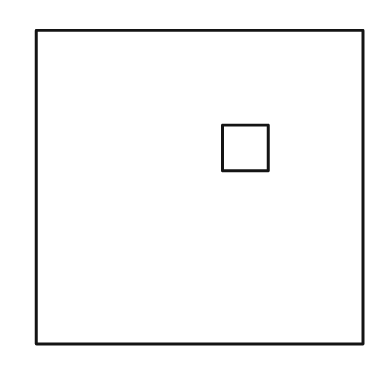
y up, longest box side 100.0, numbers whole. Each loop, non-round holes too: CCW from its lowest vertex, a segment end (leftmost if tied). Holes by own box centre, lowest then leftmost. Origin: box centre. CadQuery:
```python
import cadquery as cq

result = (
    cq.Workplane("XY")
    .moveTo(-50.0, -48.0)
    .lineTo(50.0, -48.0)
    .lineTo(50.0, 48.0)
    .lineTo(-50.0, 48.0)
    .close()
    .moveTo(7.0, 5.0)
    .lineTo(21.0, 5.0)
    .lineTo(21.0, 19.0)
    .lineTo(7.0, 19.0)
    .close()
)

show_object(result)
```